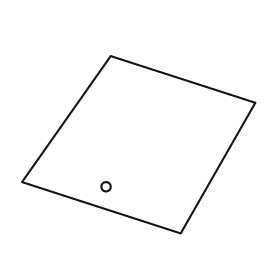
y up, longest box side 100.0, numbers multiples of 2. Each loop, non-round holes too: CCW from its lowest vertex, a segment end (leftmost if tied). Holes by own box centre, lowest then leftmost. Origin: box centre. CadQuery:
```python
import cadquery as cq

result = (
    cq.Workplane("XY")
    .moveTo(18.0, -38.0)
    .lineTo(50.0, 18.0)
    .lineTo(-12.0, 38.0)
    .lineTo(-50.0, -16.0)
    .close()
    .moveTo(-14.0, -18.0)
    .circle(2.0)
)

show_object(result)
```